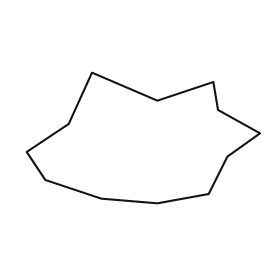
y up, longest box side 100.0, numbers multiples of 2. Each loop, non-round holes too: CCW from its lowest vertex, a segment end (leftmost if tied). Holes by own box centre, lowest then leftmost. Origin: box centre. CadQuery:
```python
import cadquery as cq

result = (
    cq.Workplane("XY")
    .moveTo(6.0, -28.0)
    .lineTo(28.0, -24.0)
    .lineTo(36.0, -8.0)
    .lineTo(50.0, 2.0)
    .lineTo(32.0, 12.0)
    .lineTo(30.0, 24.0)
    .lineTo(6.0, 16.0)
    .lineTo(-22.0, 28.0)
    .lineTo(-32.0, 6.0)
    .lineTo(-50.0, -6.0)
    .lineTo(-42.0, -18.0)
    .lineTo(-18.0, -26.0)
    .close()
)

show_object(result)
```